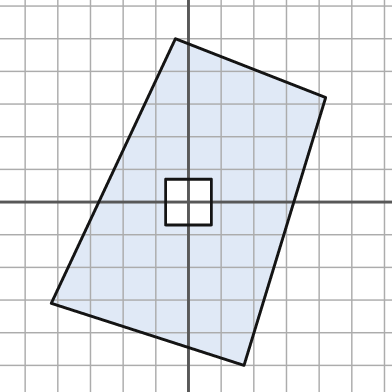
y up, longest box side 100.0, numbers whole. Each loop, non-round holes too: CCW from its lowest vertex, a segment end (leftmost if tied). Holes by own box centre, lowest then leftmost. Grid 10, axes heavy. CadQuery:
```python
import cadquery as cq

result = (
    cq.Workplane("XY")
    .moveTo(17.0, -50.0)
    .lineTo(42.0, 32.0)
    .lineTo(-4.0, 50.0)
    .lineTo(-42.0, -31.0)
    .close()
    .moveTo(-7.0, -7.0)
    .lineTo(7.0, -7.0)
    .lineTo(7.0, 7.0)
    .lineTo(-7.0, 7.0)
    .close()
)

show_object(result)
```